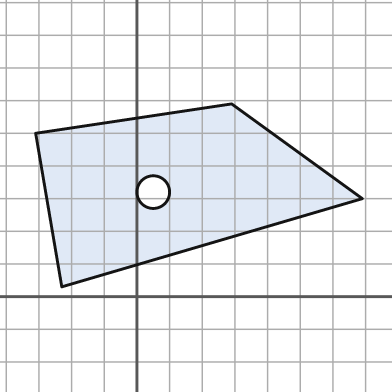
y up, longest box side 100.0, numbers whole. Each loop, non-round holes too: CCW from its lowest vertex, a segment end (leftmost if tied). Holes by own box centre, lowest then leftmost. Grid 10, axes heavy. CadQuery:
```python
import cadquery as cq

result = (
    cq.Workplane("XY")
    .moveTo(-23.0, 3.0)
    .lineTo(69.0, 30.0)
    .lineTo(29.0, 59.0)
    .lineTo(-31.0, 50.0)
    .close()
    .moveTo(5.0, 32.0)
    .circle(5.0)
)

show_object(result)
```